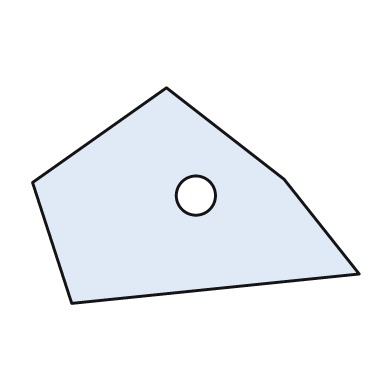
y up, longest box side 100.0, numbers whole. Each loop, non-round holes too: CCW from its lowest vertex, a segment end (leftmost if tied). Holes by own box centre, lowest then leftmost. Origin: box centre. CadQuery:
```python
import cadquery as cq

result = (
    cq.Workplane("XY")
    .moveTo(-38.0, -33.0)
    .lineTo(50.0, -24.0)
    .lineTo(27.0, 5.0)
    .lineTo(-9.0, 33.0)
    .lineTo(-50.0, 4.0)
    .close()
    .moveTo(0.0, 0.0)
    .circle(6.0)
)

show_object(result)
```